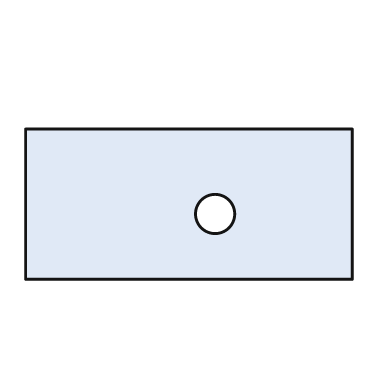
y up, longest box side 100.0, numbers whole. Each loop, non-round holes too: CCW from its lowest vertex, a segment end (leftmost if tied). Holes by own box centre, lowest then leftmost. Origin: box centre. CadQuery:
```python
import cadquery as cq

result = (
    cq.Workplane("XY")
    .moveTo(-50.0, -23.0)
    .lineTo(50.0, -23.0)
    .lineTo(50.0, 23.0)
    .lineTo(-50.0, 23.0)
    .close()
    .moveTo(8.0, -3.0)
    .circle(6.0)
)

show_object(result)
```